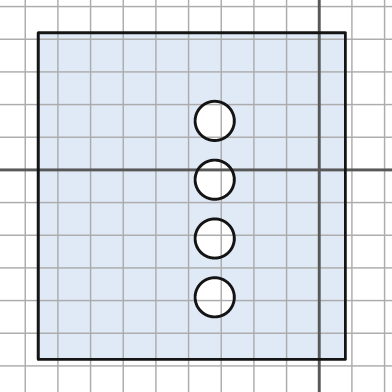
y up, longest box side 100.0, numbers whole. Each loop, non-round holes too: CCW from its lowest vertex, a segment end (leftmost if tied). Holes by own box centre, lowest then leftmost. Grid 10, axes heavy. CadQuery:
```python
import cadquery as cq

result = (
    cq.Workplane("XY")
    .moveTo(-86.0, -58.0)
    .lineTo(8.0, -58.0)
    .lineTo(8.0, 42.0)
    .lineTo(-86.0, 42.0)
    .close()
    .moveTo(-32.0, -39.0)
    .circle(6.0)
    .moveTo(-32.0, -21.0)
    .circle(6.0)
    .moveTo(-32.0, -3.0)
    .circle(6.0)
    .moveTo(-32.0, 15.0)
    .circle(6.0)
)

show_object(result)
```